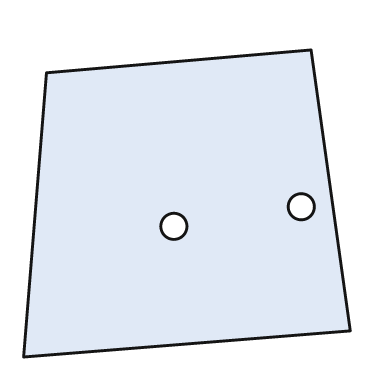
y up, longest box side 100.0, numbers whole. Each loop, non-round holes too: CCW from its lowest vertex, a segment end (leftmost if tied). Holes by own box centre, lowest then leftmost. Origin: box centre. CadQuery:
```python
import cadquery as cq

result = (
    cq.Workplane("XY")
    .moveTo(-50.0, -47.0)
    .lineTo(50.0, -39.0)
    .lineTo(38.0, 47.0)
    .lineTo(-43.0, 40.0)
    .close()
    .moveTo(-4.0, -7.0)
    .circle(4.0)
    .moveTo(35.0, -1.0)
    .circle(4.0)
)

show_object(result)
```